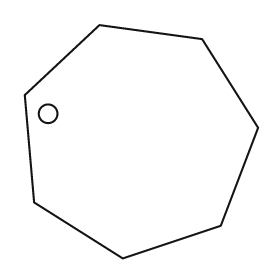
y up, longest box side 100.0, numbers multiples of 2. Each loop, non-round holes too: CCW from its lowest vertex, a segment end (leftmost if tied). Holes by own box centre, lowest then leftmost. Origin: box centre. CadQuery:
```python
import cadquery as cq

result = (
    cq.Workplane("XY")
    .moveTo(-8.0, -50.0)
    .lineTo(34.0, -36.0)
    .lineTo(50.0, 6.0)
    .lineTo(26.0, 44.0)
    .lineTo(-18.0, 50.0)
    .lineTo(-50.0, 20.0)
    .lineTo(-46.0, -26.0)
    .close()
    .moveTo(-40.0, 12.0)
    .circle(4.0)
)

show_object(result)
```